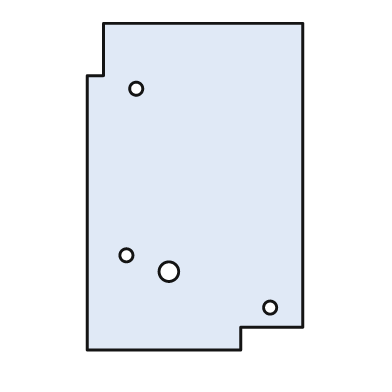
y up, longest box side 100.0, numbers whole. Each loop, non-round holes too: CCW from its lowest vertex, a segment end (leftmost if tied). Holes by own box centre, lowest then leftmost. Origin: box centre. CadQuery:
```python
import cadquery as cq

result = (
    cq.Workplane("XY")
    .moveTo(-33.0, -50.0)
    .lineTo(14.0, -50.0)
    .lineTo(14.0, -43.0)
    .lineTo(33.0, -43.0)
    .lineTo(33.0, 50.0)
    .lineTo(-28.0, 50.0)
    .lineTo(-28.0, 34.0)
    .lineTo(-33.0, 34.0)
    .close()
    .moveTo(23.0, -37.0)
    .circle(2.0)
    .moveTo(-8.0, -26.0)
    .circle(3.0)
    .moveTo(-21.0, -21.0)
    .circle(2.0)
    .moveTo(-18.0, 30.0)
    .circle(2.0)
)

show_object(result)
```